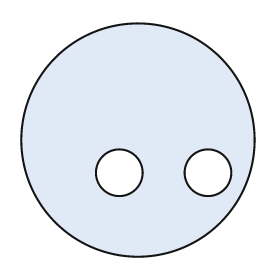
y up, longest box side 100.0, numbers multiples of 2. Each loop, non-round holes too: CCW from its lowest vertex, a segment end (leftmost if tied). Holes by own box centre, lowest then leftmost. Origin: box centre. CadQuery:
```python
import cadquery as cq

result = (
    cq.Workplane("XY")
    .moveTo(0.0, 0.0)
    .circle(50.0)
    .moveTo(-8.0, -14.0)
    .circle(10.0)
    .moveTo(30.0, -14.0)
    .circle(10.0)
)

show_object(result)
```